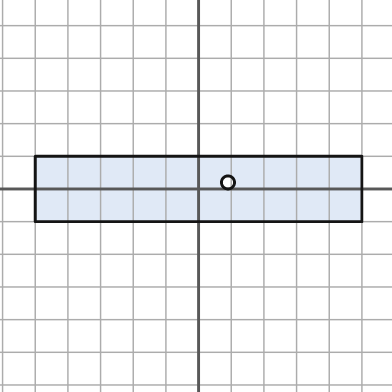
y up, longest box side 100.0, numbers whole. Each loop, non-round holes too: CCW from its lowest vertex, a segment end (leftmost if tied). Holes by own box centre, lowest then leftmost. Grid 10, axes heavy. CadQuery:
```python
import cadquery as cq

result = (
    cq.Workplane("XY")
    .moveTo(-50.0, -10.0)
    .lineTo(50.0, -10.0)
    .lineTo(50.0, 10.0)
    .lineTo(-50.0, 10.0)
    .close()
    .moveTo(9.0, 2.0)
    .circle(2.0)
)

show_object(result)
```